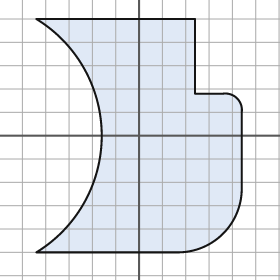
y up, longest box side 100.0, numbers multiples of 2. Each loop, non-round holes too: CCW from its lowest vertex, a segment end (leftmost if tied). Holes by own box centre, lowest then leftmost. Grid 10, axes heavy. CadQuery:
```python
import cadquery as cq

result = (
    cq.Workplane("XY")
    .moveTo(-44.0, -50.0)
    .lineTo(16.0, -50.0)
    .threePointArc((36.0, -42.0), (44.0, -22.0))
    .lineTo(44.0, 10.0)
    .threePointArc((42.0, 16.0), (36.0, 18.0))
    .lineTo(24.0, 18.0)
    .lineTo(24.0, 50.0)
    .lineTo(-44.0, 50.0)
    .threePointArc((-16.0, 0.0), (-44.0, -50.0))
    .close()
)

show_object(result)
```